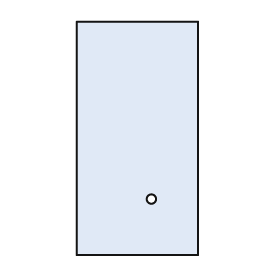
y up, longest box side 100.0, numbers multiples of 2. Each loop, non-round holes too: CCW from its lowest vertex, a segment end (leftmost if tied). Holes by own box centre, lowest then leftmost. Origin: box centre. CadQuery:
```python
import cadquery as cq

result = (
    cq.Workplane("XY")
    .moveTo(-26.0, -50.0)
    .lineTo(26.0, -50.0)
    .lineTo(26.0, 50.0)
    .lineTo(-26.0, 50.0)
    .close()
    .moveTo(6.0, -26.0)
    .circle(2.0)
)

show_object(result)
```